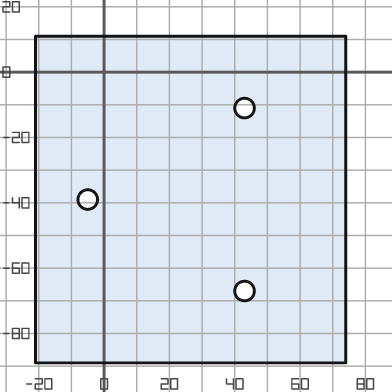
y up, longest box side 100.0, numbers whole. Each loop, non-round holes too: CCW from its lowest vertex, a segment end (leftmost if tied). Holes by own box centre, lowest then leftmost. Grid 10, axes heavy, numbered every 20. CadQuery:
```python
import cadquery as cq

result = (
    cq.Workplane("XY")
    .moveTo(-21.0, -89.0)
    .lineTo(74.0, -89.0)
    .lineTo(74.0, 11.0)
    .lineTo(-21.0, 11.0)
    .close()
    .moveTo(43.0, -67.0)
    .circle(3.0)
    .moveTo(-5.0, -39.0)
    .circle(3.0)
    .moveTo(43.0, -11.0)
    .circle(3.0)
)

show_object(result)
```